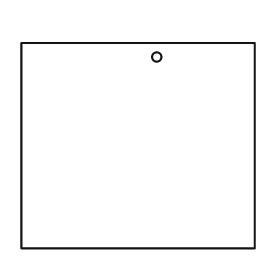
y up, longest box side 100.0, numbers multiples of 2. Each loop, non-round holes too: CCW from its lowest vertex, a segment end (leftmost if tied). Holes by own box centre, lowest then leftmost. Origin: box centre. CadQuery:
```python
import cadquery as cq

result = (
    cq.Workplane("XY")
    .moveTo(-50.0, -44.0)
    .lineTo(50.0, -44.0)
    .lineTo(50.0, 44.0)
    .lineTo(-50.0, 44.0)
    .close()
    .moveTo(8.0, 38.0)
    .circle(2.0)
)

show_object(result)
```